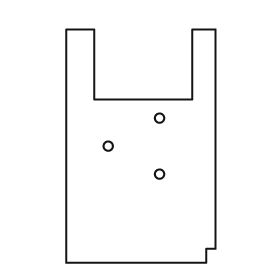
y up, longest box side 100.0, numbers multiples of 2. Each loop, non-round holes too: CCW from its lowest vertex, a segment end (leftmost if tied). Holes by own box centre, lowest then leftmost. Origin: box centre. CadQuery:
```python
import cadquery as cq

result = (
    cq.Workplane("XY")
    .moveTo(-32.0, -50.0)
    .lineTo(28.0, -50.0)
    .lineTo(28.0, -44.0)
    .lineTo(32.0, -44.0)
    .lineTo(32.0, 50.0)
    .lineTo(22.0, 50.0)
    .lineTo(22.0, 20.0)
    .lineTo(-20.0, 20.0)
    .lineTo(-20.0, 50.0)
    .lineTo(-32.0, 50.0)
    .close()
    .moveTo(8.0, -12.0)
    .circle(2.0)
    .moveTo(-14.0, 0.0)
    .circle(2.0)
    .moveTo(8.0, 12.0)
    .circle(2.0)
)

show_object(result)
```